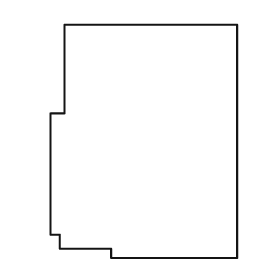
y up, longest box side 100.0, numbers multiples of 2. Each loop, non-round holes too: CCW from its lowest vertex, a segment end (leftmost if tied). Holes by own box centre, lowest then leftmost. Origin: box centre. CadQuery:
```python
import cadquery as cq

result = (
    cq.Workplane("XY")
    .moveTo(-14.0, -50.0)
    .lineTo(40.0, -50.0)
    .lineTo(40.0, 50.0)
    .lineTo(-34.0, 50.0)
    .lineTo(-34.0, 12.0)
    .lineTo(-40.0, 12.0)
    .lineTo(-40.0, -40.0)
    .lineTo(-36.0, -40.0)
    .lineTo(-36.0, -46.0)
    .lineTo(-14.0, -46.0)
    .close()
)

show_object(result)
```